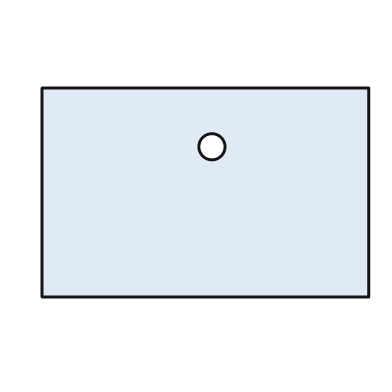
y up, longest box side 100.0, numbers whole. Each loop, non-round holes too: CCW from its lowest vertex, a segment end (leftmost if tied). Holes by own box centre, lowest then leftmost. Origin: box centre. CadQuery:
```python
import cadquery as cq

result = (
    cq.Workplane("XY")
    .moveTo(-50.0, -32.0)
    .lineTo(50.0, -32.0)
    .lineTo(50.0, 32.0)
    .lineTo(-50.0, 32.0)
    .close()
    .moveTo(2.0, 14.0)
    .circle(4.0)
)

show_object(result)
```